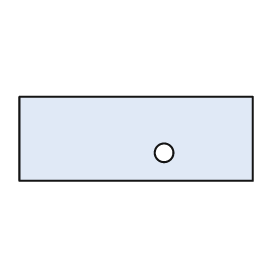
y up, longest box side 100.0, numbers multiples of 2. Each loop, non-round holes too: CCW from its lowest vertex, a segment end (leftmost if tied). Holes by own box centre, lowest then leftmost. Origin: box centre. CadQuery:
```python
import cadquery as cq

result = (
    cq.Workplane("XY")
    .moveTo(-50.0, -18.0)
    .lineTo(50.0, -18.0)
    .lineTo(50.0, 18.0)
    .lineTo(-50.0, 18.0)
    .close()
    .moveTo(12.0, -6.0)
    .circle(4.0)
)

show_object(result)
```